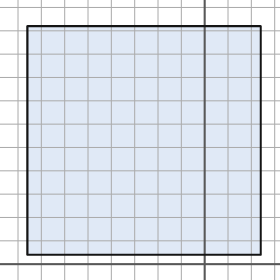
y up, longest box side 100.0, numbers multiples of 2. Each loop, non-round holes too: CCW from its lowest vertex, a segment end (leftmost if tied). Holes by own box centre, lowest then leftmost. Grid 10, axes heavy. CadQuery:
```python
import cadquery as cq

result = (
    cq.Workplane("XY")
    .moveTo(-76.0, 4.0)
    .lineTo(24.0, 4.0)
    .lineTo(24.0, 102.0)
    .lineTo(-76.0, 102.0)
    .close()
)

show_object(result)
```